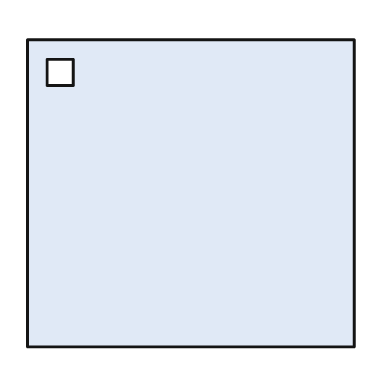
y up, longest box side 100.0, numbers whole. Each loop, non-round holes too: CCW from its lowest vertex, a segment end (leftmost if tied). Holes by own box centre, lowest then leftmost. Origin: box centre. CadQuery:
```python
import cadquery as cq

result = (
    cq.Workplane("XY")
    .moveTo(-50.0, -47.0)
    .lineTo(50.0, -47.0)
    .lineTo(50.0, 47.0)
    .lineTo(-50.0, 47.0)
    .close()
    .moveTo(-44.0, 33.0)
    .lineTo(-36.0, 33.0)
    .lineTo(-36.0, 41.0)
    .lineTo(-44.0, 41.0)
    .close()
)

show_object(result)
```